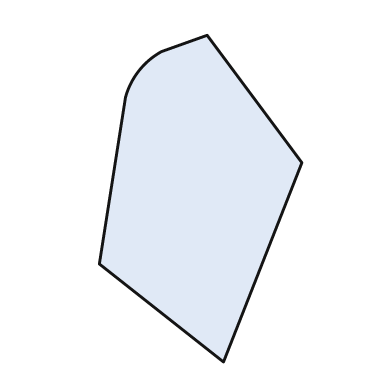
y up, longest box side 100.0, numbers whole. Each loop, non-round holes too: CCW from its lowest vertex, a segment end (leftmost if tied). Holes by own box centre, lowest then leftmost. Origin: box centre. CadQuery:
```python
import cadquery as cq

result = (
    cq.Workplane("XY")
    .moveTo(7.0, -50.0)
    .lineTo(31.0, 11.0)
    .lineTo(2.0, 50.0)
    .lineTo(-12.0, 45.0)
    .threePointArc((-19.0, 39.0), (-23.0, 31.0))
    .lineTo(-31.0, -20.0)
    .close()
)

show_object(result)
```